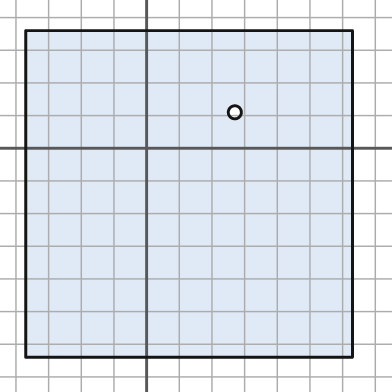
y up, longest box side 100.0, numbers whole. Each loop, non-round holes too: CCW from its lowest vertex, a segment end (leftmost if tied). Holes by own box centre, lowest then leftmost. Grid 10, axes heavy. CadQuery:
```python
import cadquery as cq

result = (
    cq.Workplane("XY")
    .moveTo(-37.0, -64.0)
    .lineTo(63.0, -64.0)
    .lineTo(63.0, 36.0)
    .lineTo(-37.0, 36.0)
    .close()
    .moveTo(27.0, 11.0)
    .circle(2.0)
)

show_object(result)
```